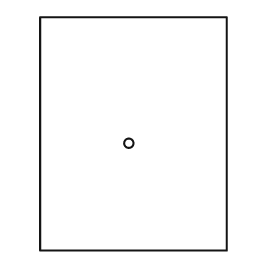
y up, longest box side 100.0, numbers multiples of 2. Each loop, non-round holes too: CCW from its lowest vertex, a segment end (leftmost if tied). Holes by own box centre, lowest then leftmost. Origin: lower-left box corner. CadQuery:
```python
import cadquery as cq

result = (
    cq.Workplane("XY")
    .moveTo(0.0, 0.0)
    .lineTo(80.0, 0.0)
    .lineTo(80.0, 100.0)
    .lineTo(0.0, 100.0)
    .close()
    .moveTo(38.0, 46.0)
    .circle(2.0)
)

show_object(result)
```